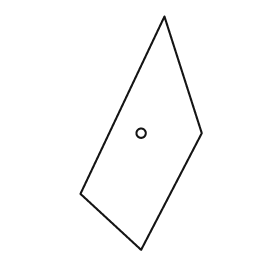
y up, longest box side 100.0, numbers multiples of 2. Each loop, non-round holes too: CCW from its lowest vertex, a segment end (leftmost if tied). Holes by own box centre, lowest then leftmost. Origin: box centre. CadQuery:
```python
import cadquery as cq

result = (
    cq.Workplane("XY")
    .moveTo(0.0, -50.0)
    .lineTo(26.0, 0.0)
    .lineTo(10.0, 50.0)
    .lineTo(-26.0, -26.0)
    .close()
    .moveTo(0.0, 0.0)
    .circle(2.0)
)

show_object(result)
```